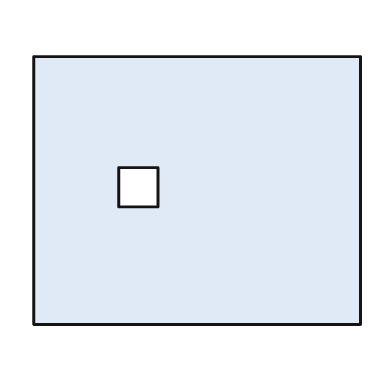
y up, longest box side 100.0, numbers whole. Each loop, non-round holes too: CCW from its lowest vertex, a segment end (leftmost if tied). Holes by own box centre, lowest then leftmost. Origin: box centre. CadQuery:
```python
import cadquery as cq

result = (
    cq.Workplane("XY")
    .moveTo(-50.0, -41.0)
    .lineTo(50.0, -41.0)
    .lineTo(50.0, 41.0)
    .lineTo(-50.0, 41.0)
    .close()
    .moveTo(-24.0, -5.0)
    .lineTo(-12.0, -5.0)
    .lineTo(-12.0, 7.0)
    .lineTo(-24.0, 7.0)
    .close()
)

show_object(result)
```